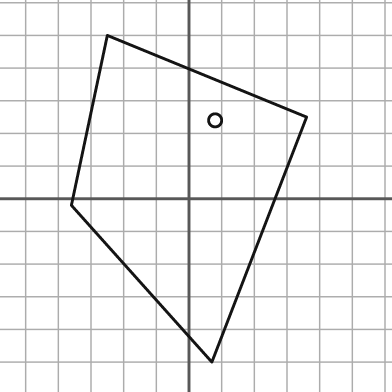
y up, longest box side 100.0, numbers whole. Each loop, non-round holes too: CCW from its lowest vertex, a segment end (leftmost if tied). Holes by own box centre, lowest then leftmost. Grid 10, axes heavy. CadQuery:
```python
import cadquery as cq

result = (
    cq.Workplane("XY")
    .moveTo(7.0, -50.0)
    .lineTo(36.0, 25.0)
    .lineTo(-25.0, 50.0)
    .lineTo(-36.0, -2.0)
    .close()
    .moveTo(8.0, 24.0)
    .circle(2.0)
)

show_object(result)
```